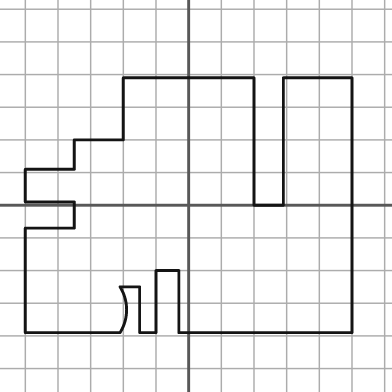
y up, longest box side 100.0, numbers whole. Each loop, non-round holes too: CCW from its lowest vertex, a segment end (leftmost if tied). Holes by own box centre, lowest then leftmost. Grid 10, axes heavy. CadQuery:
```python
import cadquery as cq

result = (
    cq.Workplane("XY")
    .moveTo(-50.0, -39.0)
    .lineTo(-21.0, -39.0)
    .threePointArc((-19.0, -32.0), (-21.0, -25.0))
    .lineTo(-15.0, -25.0)
    .lineTo(-15.0, -39.0)
    .lineTo(-10.0, -39.0)
    .lineTo(-10.0, -20.0)
    .lineTo(-3.0, -20.0)
    .lineTo(-3.0, -39.0)
    .lineTo(50.0, -39.0)
    .lineTo(50.0, 39.0)
    .lineTo(29.0, 39.0)
    .lineTo(29.0, 0.0)
    .lineTo(20.0, 0.0)
    .lineTo(20.0, 39.0)
    .lineTo(-20.0, 39.0)
    .lineTo(-20.0, 20.0)
    .lineTo(-35.0, 20.0)
    .lineTo(-35.0, 11.0)
    .lineTo(-50.0, 11.0)
    .lineTo(-50.0, 1.0)
    .lineTo(-35.0, 1.0)
    .lineTo(-35.0, -7.0)
    .lineTo(-50.0, -7.0)
    .close()
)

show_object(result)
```